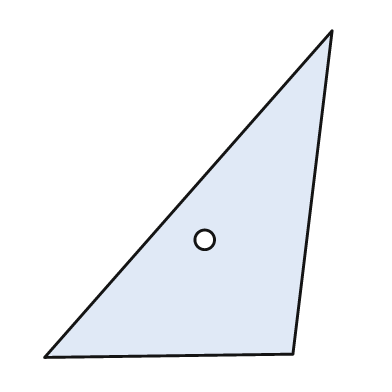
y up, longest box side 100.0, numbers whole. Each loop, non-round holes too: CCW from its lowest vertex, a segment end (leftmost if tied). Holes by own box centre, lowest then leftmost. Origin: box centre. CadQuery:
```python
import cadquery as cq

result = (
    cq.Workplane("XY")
    .moveTo(-44.0, -50.0)
    .lineTo(32.0, -49.0)
    .lineTo(44.0, 50.0)
    .close()
    .moveTo(5.0, -14.0)
    .circle(3.0)
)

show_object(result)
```